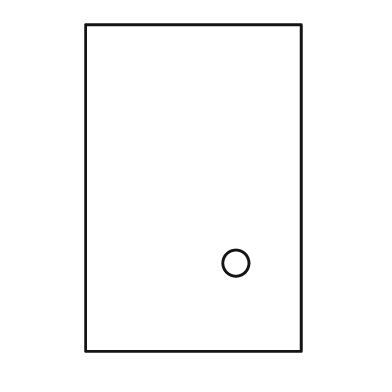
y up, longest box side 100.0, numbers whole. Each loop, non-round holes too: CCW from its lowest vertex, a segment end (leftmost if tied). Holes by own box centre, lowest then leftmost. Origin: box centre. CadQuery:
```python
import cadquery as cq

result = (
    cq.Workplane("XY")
    .moveTo(-33.0, -50.0)
    .lineTo(33.0, -50.0)
    .lineTo(33.0, 50.0)
    .lineTo(-33.0, 50.0)
    .close()
    .moveTo(13.0, -23.0)
    .circle(4.0)
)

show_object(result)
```